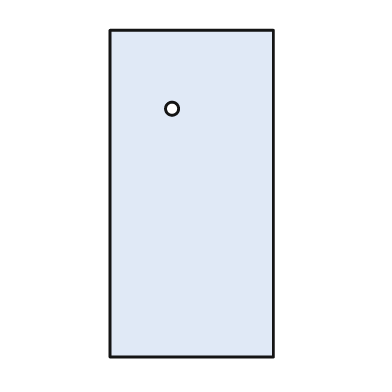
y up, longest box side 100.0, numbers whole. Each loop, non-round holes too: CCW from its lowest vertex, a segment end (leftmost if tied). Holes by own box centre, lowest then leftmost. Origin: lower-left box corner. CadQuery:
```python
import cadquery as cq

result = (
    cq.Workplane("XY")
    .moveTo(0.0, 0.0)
    .lineTo(50.0, 0.0)
    .lineTo(50.0, 100.0)
    .lineTo(0.0, 100.0)
    .close()
    .moveTo(19.0, 76.0)
    .circle(2.0)
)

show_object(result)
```